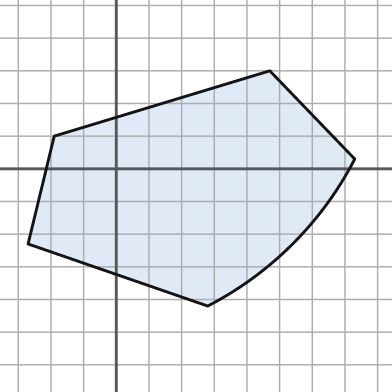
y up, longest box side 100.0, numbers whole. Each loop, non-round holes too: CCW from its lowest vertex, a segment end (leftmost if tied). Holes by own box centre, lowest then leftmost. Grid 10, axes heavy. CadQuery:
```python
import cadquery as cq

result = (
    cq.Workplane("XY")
    .moveTo(28.0, -42.0)
    .threePointArc((54.0, -23.0), (73.0, 3.0))
    .lineTo(47.0, 30.0)
    .lineTo(-19.0, 10.0)
    .lineTo(-27.0, -23.0)
    .close()
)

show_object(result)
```